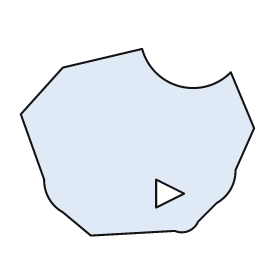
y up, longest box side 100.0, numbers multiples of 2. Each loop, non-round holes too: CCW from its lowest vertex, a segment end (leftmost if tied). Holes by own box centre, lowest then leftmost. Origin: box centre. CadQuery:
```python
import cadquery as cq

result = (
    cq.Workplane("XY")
    .moveTo(-20.0, -40.0)
    .lineTo(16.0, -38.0)
    .threePointArc((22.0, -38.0), (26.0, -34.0))
    .lineTo(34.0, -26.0)
    .threePointArc((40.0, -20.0), (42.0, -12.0))
    .lineTo(50.0, 6.0)
    .lineTo(40.0, 30.0)
    .threePointArc((18.0, 24.0), (2.0, 40.0))
    .lineTo(-32.0, 32.0)
    .lineTo(-50.0, 12.0)
    .lineTo(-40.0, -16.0)
    .threePointArc((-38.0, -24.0), (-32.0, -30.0))
    .close()
    .moveTo(8.0, -28.0)
    .lineTo(20.0, -22.0)
    .lineTo(8.0, -16.0)
    .close()
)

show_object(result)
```